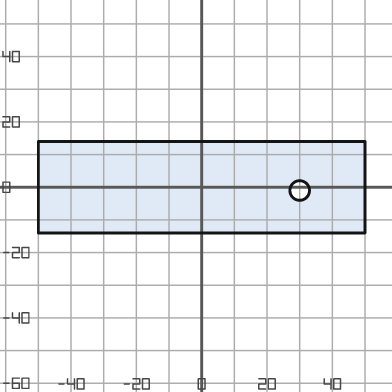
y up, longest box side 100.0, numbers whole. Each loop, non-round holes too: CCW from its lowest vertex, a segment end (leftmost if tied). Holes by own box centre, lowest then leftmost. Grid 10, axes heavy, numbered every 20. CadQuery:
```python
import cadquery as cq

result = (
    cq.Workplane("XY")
    .moveTo(-50.0, -14.0)
    .lineTo(50.0, -14.0)
    .lineTo(50.0, 14.0)
    .lineTo(-50.0, 14.0)
    .close()
    .moveTo(30.0, -1.0)
    .circle(3.0)
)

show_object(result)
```